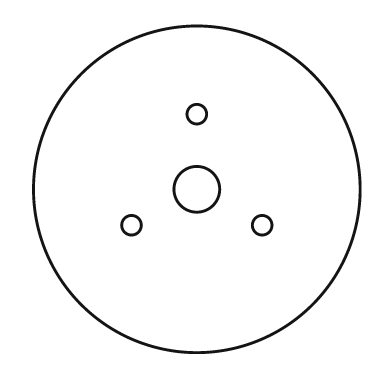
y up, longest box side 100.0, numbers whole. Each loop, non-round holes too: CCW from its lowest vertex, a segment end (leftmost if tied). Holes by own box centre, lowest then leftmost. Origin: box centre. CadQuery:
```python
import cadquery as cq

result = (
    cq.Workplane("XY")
    .moveTo(0.0, 0.0)
    .circle(50.0)
    .moveTo(-20.0, -11.0)
    .circle(3.0)
    .moveTo(20.0, -11.0)
    .circle(3.0)
    .moveTo(0.0, 0.0)
    .circle(7.0)
    .moveTo(0.0, 23.0)
    .circle(3.0)
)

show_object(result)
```